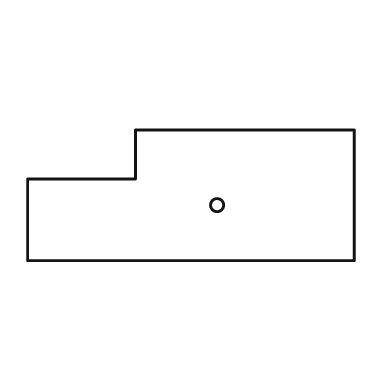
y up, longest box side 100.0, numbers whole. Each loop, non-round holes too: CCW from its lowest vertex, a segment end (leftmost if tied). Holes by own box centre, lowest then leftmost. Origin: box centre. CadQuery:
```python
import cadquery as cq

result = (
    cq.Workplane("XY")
    .moveTo(-50.0, -20.0)
    .lineTo(50.0, -20.0)
    .lineTo(50.0, 20.0)
    .lineTo(-17.0, 20.0)
    .lineTo(-17.0, 5.0)
    .lineTo(-50.0, 5.0)
    .close()
    .moveTo(8.0, -3.0)
    .circle(2.0)
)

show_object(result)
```